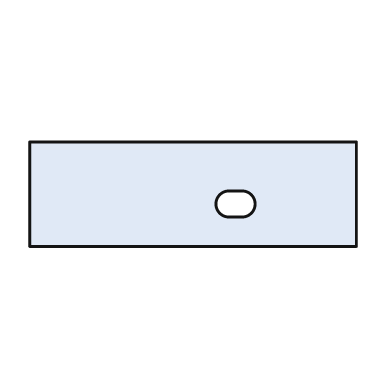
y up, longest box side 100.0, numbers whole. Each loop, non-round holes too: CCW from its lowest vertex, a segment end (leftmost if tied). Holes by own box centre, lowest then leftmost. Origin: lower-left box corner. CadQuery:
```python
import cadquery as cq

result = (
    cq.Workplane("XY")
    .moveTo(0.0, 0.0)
    .lineTo(100.0, 0.0)
    .lineTo(100.0, 32.0)
    .lineTo(0.0, 32.0)
    .close()
    .moveTo(61.0, 9.0)
    .lineTo(65.0, 9.0)
    .threePointArc((69.0, 13.0), (65.0, 17.0))
    .lineTo(61.0, 17.0)
    .threePointArc((57.0, 13.0), (61.0, 9.0))
    .close()
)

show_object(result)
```